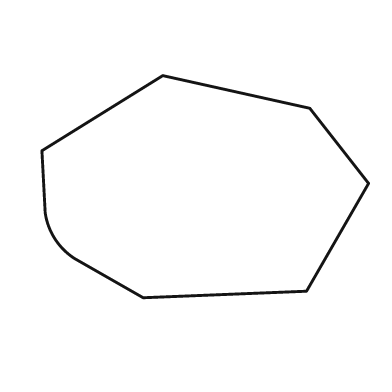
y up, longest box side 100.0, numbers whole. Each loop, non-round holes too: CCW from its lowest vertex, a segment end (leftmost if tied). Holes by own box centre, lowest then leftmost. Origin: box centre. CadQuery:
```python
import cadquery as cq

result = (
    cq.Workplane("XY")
    .moveTo(-19.0, -34.0)
    .lineTo(31.0, -32.0)
    .lineTo(50.0, 1.0)
    .lineTo(32.0, 24.0)
    .lineTo(-13.0, 34.0)
    .lineTo(-50.0, 11.0)
    .lineTo(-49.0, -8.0)
    .threePointArc((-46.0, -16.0), (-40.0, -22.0))
    .close()
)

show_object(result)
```